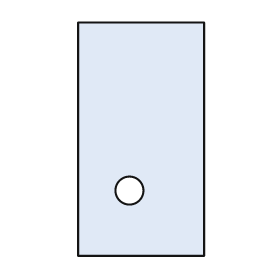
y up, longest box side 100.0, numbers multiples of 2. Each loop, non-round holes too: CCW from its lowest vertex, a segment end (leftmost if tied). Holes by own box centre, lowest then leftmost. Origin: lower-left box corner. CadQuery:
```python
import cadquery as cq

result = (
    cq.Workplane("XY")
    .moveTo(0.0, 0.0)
    .lineTo(54.0, 0.0)
    .lineTo(54.0, 100.0)
    .lineTo(0.0, 100.0)
    .close()
    .moveTo(22.0, 28.0)
    .circle(6.0)
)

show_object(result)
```